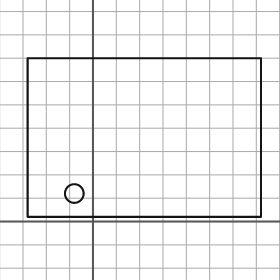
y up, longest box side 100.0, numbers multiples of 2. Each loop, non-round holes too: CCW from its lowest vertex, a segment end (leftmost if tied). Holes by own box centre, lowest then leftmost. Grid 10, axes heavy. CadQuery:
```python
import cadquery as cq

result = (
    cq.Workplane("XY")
    .moveTo(-28.0, 2.0)
    .lineTo(72.0, 2.0)
    .lineTo(72.0, 70.0)
    .lineTo(-28.0, 70.0)
    .close()
    .moveTo(-8.0, 12.0)
    .circle(4.0)
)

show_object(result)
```